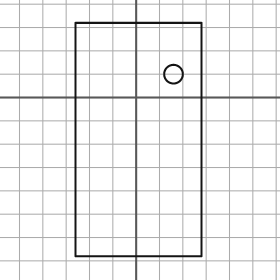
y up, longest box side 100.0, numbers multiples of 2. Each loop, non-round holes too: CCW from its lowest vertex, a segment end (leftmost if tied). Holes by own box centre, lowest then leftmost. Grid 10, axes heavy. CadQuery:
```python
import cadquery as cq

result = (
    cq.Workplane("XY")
    .moveTo(-26.0, -68.0)
    .lineTo(28.0, -68.0)
    .lineTo(28.0, 32.0)
    .lineTo(-26.0, 32.0)
    .close()
    .moveTo(16.0, 10.0)
    .circle(4.0)
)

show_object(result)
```